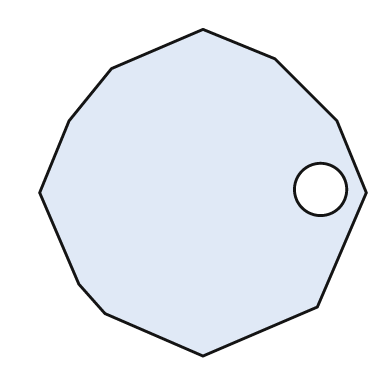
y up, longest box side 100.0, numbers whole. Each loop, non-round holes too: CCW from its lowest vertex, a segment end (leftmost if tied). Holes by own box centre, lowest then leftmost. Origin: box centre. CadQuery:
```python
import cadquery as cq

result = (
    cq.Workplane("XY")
    .moveTo(0.0, -50.0)
    .lineTo(35.0, -35.0)
    .lineTo(50.0, 0.0)
    .lineTo(41.0, 22.0)
    .lineTo(22.0, 41.0)
    .lineTo(0.0, 50.0)
    .lineTo(-28.0, 38.0)
    .lineTo(-41.0, 22.0)
    .lineTo(-50.0, 0.0)
    .lineTo(-38.0, -28.0)
    .lineTo(-30.0, -37.0)
    .close()
    .moveTo(36.0, 1.0)
    .circle(8.0)
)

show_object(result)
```